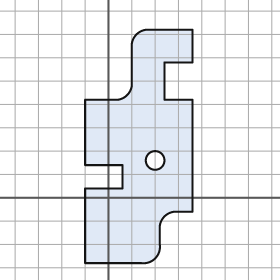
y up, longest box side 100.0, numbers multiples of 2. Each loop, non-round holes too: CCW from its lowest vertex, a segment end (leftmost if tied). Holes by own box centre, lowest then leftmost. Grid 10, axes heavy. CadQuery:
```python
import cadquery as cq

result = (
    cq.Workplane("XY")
    .moveTo(-10.0, -28.0)
    .lineTo(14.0, -28.0)
    .threePointArc((20.0, -26.0), (22.0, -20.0))
    .lineTo(22.0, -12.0)
    .threePointArc((24.0, -8.0), (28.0, -6.0))
    .lineTo(36.0, -6.0)
    .lineTo(36.0, 42.0)
    .lineTo(24.0, 42.0)
    .lineTo(24.0, 58.0)
    .lineTo(36.0, 58.0)
    .lineTo(36.0, 72.0)
    .lineTo(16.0, 72.0)
    .threePointArc((12.0, 70.0), (10.0, 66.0))
    .lineTo(10.0, 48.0)
    .threePointArc((8.0, 44.0), (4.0, 42.0))
    .lineTo(-10.0, 42.0)
    .lineTo(-10.0, 14.0)
    .lineTo(6.0, 14.0)
    .lineTo(6.0, 4.0)
    .lineTo(-10.0, 4.0)
    .close()
    .moveTo(20.0, 16.0)
    .circle(4.0)
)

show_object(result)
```